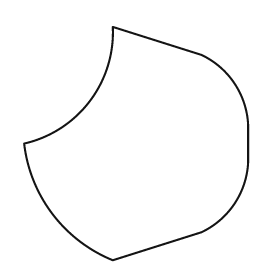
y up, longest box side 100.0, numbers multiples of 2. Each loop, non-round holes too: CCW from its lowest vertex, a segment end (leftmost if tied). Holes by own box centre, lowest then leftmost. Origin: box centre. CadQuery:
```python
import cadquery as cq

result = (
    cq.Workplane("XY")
    .moveTo(-10.0, -50.0)
    .lineTo(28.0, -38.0)
    .threePointArc((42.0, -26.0), (48.0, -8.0))
    .lineTo(48.0, 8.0)
    .threePointArc((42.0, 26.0), (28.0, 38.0))
    .lineTo(-10.0, 50.0)
    .threePointArc((-20.0, 18.0), (-48.0, 0.0))
    .threePointArc((-36.0, -30.0), (-10.0, -50.0))
    .close()
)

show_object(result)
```